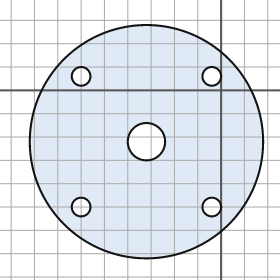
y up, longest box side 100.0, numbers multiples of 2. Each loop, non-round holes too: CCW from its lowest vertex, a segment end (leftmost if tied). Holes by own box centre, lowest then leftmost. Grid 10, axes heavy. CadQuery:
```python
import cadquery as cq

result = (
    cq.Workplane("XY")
    .moveTo(-32.0, -22.0)
    .circle(50.0)
    .moveTo(-60.0, -50.0)
    .circle(4.0)
    .moveTo(-4.0, -50.0)
    .circle(4.0)
    .moveTo(-32.0, -22.0)
    .circle(8.0)
    .moveTo(-60.0, 6.0)
    .circle(4.0)
    .moveTo(-4.0, 6.0)
    .circle(4.0)
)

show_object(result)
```